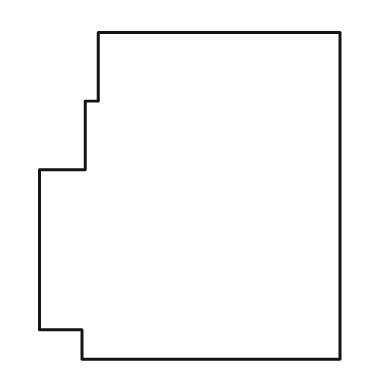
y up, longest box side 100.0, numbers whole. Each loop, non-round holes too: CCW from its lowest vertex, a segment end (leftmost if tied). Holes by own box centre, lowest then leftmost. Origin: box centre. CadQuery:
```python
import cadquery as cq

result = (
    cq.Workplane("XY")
    .moveTo(-33.0, -50.0)
    .lineTo(46.0, -50.0)
    .lineTo(46.0, 50.0)
    .lineTo(-28.0, 50.0)
    .lineTo(-28.0, 29.0)
    .lineTo(-32.0, 29.0)
    .lineTo(-32.0, 8.0)
    .lineTo(-46.0, 8.0)
    .lineTo(-46.0, -41.0)
    .lineTo(-33.0, -41.0)
    .close()
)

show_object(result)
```